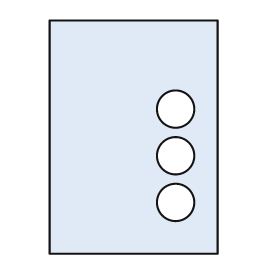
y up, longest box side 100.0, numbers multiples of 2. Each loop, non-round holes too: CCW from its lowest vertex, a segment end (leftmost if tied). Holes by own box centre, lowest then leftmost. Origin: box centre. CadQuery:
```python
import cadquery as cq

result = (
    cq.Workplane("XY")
    .moveTo(-36.0, -50.0)
    .lineTo(36.0, -50.0)
    .lineTo(36.0, 50.0)
    .lineTo(-36.0, 50.0)
    .close()
    .moveTo(18.0, -28.0)
    .circle(8.0)
    .moveTo(18.0, -8.0)
    .circle(8.0)
    .moveTo(18.0, 12.0)
    .circle(8.0)
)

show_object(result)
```